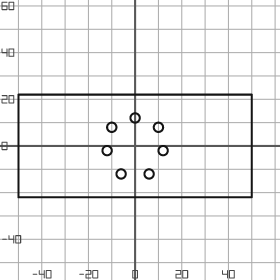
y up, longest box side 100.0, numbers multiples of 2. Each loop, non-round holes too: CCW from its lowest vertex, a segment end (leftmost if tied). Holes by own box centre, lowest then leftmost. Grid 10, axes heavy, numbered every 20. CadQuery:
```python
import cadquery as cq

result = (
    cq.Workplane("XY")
    .moveTo(-50.0, -22.0)
    .lineTo(50.0, -22.0)
    .lineTo(50.0, 22.0)
    .lineTo(-50.0, 22.0)
    .close()
    .moveTo(-6.0, -12.0)
    .circle(2.0)
    .moveTo(6.0, -12.0)
    .circle(2.0)
    .moveTo(-12.0, -2.0)
    .circle(2.0)
    .moveTo(12.0, -2.0)
    .circle(2.0)
    .moveTo(-10.0, 8.0)
    .circle(2.0)
    .moveTo(10.0, 8.0)
    .circle(2.0)
    .moveTo(0.0, 12.0)
    .circle(2.0)
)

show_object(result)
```